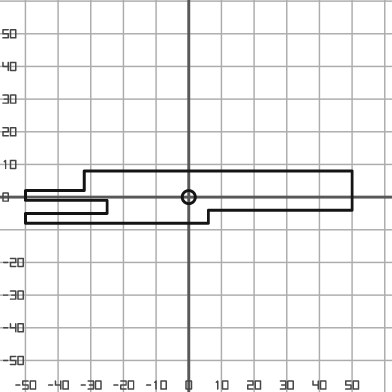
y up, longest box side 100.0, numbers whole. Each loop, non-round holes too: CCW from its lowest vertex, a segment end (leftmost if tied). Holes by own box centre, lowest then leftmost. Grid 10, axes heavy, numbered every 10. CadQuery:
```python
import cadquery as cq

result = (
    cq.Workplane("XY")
    .moveTo(-50.0, -8.0)
    .lineTo(6.0, -8.0)
    .lineTo(6.0, -4.0)
    .lineTo(50.0, -4.0)
    .lineTo(50.0, 8.0)
    .lineTo(-32.0, 8.0)
    .lineTo(-32.0, 2.0)
    .lineTo(-50.0, 2.0)
    .lineTo(-50.0, -1.0)
    .lineTo(-25.0, -1.0)
    .lineTo(-25.0, -5.0)
    .lineTo(-50.0, -5.0)
    .close()
    .moveTo(0.0, 0.0)
    .circle(2.0)
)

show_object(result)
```